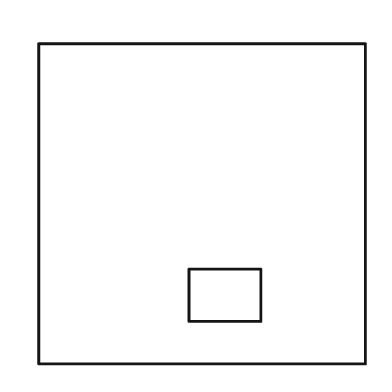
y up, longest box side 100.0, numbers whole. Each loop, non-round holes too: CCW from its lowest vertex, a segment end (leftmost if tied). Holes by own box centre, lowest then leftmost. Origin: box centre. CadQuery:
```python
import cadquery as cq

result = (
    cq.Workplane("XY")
    .moveTo(-50.0, -49.0)
    .lineTo(50.0, -49.0)
    .lineTo(50.0, 49.0)
    .lineTo(-50.0, 49.0)
    .close()
    .moveTo(-4.0, -36.0)
    .lineTo(18.0, -36.0)
    .lineTo(18.0, -20.0)
    .lineTo(-4.0, -20.0)
    .close()
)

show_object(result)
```